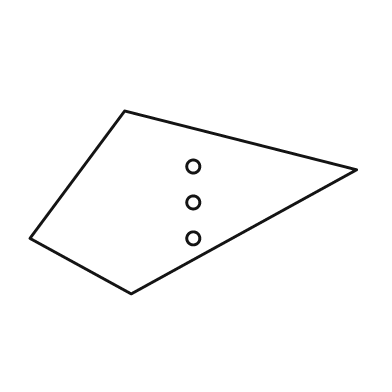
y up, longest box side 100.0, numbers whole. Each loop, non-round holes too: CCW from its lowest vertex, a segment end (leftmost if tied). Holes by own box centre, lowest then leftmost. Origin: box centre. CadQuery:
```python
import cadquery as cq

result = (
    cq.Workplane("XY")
    .moveTo(-19.0, -28.0)
    .lineTo(50.0, 10.0)
    .lineTo(-21.0, 28.0)
    .lineTo(-50.0, -11.0)
    .close()
    .moveTo(0.0, -11.0)
    .circle(2.0)
    .moveTo(0.0, 0.0)
    .circle(2.0)
    .moveTo(0.0, 11.0)
    .circle(2.0)
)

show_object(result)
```